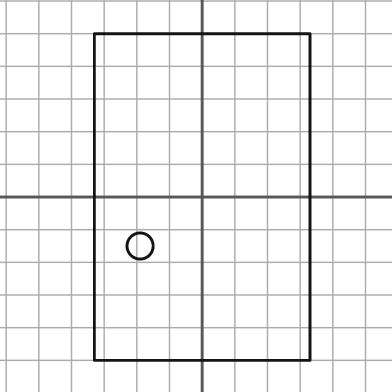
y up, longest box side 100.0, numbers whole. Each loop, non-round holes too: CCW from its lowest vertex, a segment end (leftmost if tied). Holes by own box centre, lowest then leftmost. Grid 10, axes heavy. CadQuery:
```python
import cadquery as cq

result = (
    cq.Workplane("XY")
    .moveTo(-33.0, -50.0)
    .lineTo(33.0, -50.0)
    .lineTo(33.0, 50.0)
    .lineTo(-33.0, 50.0)
    .close()
    .moveTo(-19.0, -15.0)
    .circle(4.0)
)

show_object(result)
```